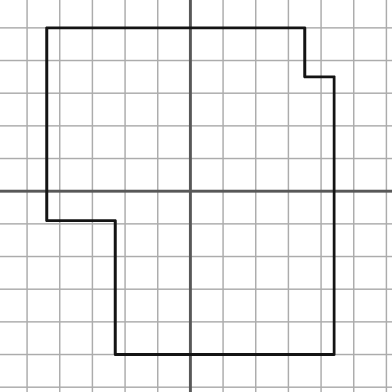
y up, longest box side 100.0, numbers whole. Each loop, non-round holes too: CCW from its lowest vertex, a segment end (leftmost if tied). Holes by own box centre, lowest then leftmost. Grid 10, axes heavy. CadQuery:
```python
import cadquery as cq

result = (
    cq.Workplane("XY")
    .moveTo(-23.0, -50.0)
    .lineTo(44.0, -50.0)
    .lineTo(44.0, 35.0)
    .lineTo(35.0, 35.0)
    .lineTo(35.0, 50.0)
    .lineTo(-44.0, 50.0)
    .lineTo(-44.0, -9.0)
    .lineTo(-23.0, -9.0)
    .close()
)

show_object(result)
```